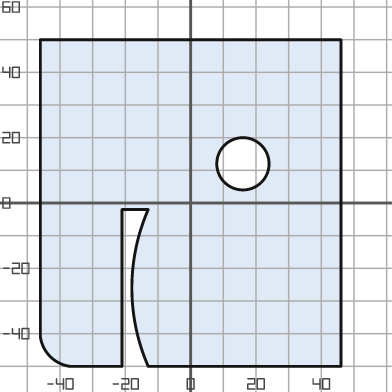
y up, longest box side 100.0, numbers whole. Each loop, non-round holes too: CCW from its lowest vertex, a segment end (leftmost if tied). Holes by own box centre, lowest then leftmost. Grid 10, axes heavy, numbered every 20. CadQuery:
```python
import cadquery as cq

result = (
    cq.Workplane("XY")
    .moveTo(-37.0, -50.0)
    .lineTo(-21.0, -50.0)
    .lineTo(-21.0, -2.0)
    .lineTo(-13.0, -2.0)
    .threePointArc((-18.0, -26.0), (-13.0, -50.0))
    .lineTo(46.0, -50.0)
    .lineTo(46.0, 50.0)
    .lineTo(-46.0, 50.0)
    .lineTo(-46.0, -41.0)
    .threePointArc((-43.0, -47.0), (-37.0, -50.0))
    .close()
    .moveTo(16.0, 12.0)
    .circle(8.0)
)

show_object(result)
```